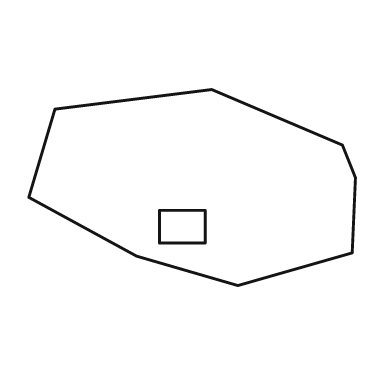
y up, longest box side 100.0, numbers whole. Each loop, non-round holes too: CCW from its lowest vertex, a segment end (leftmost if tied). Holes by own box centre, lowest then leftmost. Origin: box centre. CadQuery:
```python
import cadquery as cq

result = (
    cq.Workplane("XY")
    .moveTo(14.0, -30.0)
    .lineTo(49.0, -20.0)
    .lineTo(50.0, 3.0)
    .lineTo(46.0, 13.0)
    .lineTo(6.0, 30.0)
    .lineTo(-42.0, 24.0)
    .lineTo(-50.0, -3.0)
    .lineTo(-17.0, -21.0)
    .close()
    .moveTo(-10.0, -17.0)
    .lineTo(4.0, -17.0)
    .lineTo(4.0, -7.0)
    .lineTo(-10.0, -7.0)
    .close()
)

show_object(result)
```